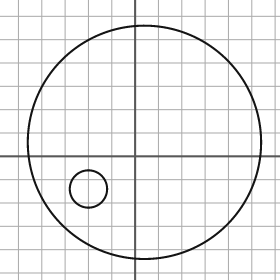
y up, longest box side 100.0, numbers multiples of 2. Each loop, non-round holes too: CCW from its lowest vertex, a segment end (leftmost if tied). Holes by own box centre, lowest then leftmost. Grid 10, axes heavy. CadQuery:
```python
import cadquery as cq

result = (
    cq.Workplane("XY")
    .moveTo(4.0, 6.0)
    .circle(50.0)
    .moveTo(-20.0, -14.0)
    .circle(8.0)
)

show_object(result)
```